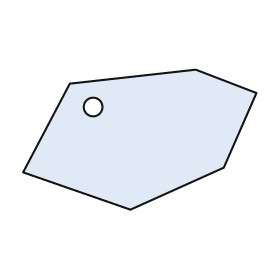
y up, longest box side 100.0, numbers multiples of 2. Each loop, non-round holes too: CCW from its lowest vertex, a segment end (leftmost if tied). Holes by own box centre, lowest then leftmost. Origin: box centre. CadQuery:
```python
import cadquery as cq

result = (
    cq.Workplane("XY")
    .moveTo(-4.0, -30.0)
    .lineTo(36.0, -12.0)
    .lineTo(50.0, 20.0)
    .lineTo(24.0, 30.0)
    .lineTo(-30.0, 24.0)
    .lineTo(-50.0, -14.0)
    .close()
    .moveTo(-20.0, 14.0)
    .circle(4.0)
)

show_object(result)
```